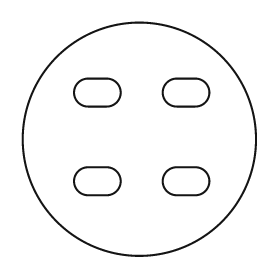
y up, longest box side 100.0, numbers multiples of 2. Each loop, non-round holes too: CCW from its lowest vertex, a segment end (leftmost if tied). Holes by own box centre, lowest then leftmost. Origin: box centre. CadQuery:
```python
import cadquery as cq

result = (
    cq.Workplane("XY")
    .moveTo(0.0, 0.0)
    .circle(50.0)
    .moveTo(-22.0, -24.0)
    .lineTo(-14.0, -24.0)
    .threePointArc((-8.0, -18.0), (-14.0, -12.0))
    .lineTo(-22.0, -12.0)
    .threePointArc((-28.0, -18.0), (-22.0, -24.0))
    .close()
    .moveTo(16.0, -24.0)
    .lineTo(24.0, -24.0)
    .threePointArc((30.0, -18.0), (24.0, -12.0))
    .lineTo(16.0, -12.0)
    .threePointArc((10.0, -18.0), (16.0, -24.0))
    .close()
    .moveTo(-22.0, 14.0)
    .lineTo(-14.0, 14.0)
    .threePointArc((-8.0, 20.0), (-14.0, 26.0))
    .lineTo(-22.0, 26.0)
    .threePointArc((-28.0, 20.0), (-22.0, 14.0))
    .close()
    .moveTo(16.0, 14.0)
    .lineTo(24.0, 14.0)
    .threePointArc((30.0, 20.0), (24.0, 26.0))
    .lineTo(16.0, 26.0)
    .threePointArc((10.0, 20.0), (16.0, 14.0))
    .close()
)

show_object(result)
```